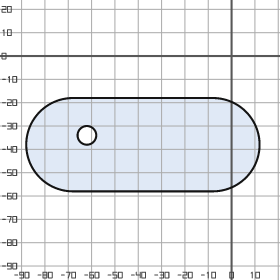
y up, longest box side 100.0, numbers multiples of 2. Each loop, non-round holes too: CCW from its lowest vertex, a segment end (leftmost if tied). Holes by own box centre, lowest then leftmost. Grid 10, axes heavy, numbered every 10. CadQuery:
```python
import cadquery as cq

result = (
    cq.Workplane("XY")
    .moveTo(-68.0, -58.0)
    .lineTo(-8.0, -58.0)
    .threePointArc((12.0, -38.0), (-8.0, -18.0))
    .lineTo(-68.0, -18.0)
    .threePointArc((-88.0, -38.0), (-68.0, -58.0))
    .close()
    .moveTo(-62.0, -34.0)
    .circle(4.0)
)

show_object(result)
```